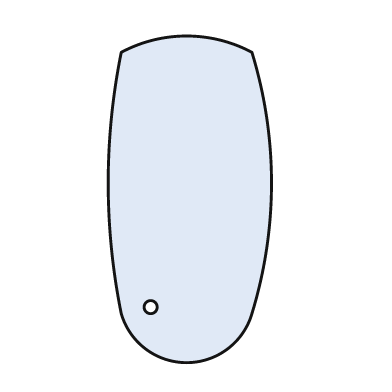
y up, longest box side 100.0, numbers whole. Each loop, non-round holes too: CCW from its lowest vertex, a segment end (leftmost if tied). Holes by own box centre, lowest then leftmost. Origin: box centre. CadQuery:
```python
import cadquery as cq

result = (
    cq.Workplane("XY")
    .moveTo(-21.0, -35.0)
    .threePointArc((-1.0, -50.0), (19.0, -35.0))
    .threePointArc((25.0, 5.0), (19.0, 45.0))
    .threePointArc((-1.0, 50.0), (-21.0, 45.0))
    .threePointArc((-25.0, 5.0), (-21.0, -35.0))
    .close()
    .moveTo(-12.0, -33.0)
    .circle(2.0)
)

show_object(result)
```